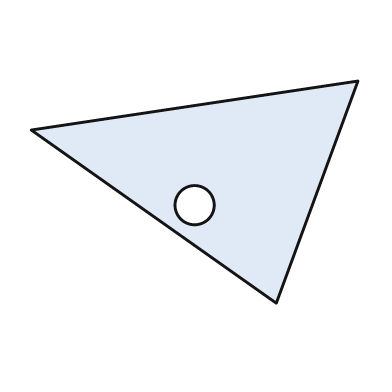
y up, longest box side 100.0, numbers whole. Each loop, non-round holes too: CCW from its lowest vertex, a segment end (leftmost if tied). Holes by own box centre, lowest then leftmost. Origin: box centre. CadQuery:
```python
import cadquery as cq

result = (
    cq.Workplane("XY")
    .moveTo(25.0, -34.0)
    .lineTo(50.0, 34.0)
    .lineTo(-50.0, 19.0)
    .close()
    .moveTo(0.0, -4.0)
    .circle(6.0)
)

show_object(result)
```